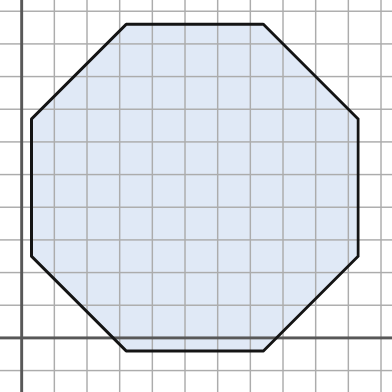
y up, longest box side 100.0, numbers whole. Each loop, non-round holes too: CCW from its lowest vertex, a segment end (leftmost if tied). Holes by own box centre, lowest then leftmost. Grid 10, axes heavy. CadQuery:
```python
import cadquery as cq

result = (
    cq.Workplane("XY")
    .moveTo(32.0, -4.0)
    .lineTo(74.0, -4.0)
    .lineTo(103.0, 25.0)
    .lineTo(103.0, 67.0)
    .lineTo(74.0, 96.0)
    .lineTo(32.0, 96.0)
    .lineTo(3.0, 67.0)
    .lineTo(3.0, 25.0)
    .close()
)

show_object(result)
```